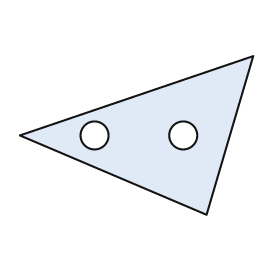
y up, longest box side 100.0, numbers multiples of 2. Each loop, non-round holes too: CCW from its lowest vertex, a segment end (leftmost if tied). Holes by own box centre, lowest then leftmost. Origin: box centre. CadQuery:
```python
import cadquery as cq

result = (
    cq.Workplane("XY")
    .moveTo(30.0, -34.0)
    .lineTo(50.0, 34.0)
    .lineTo(-50.0, 0.0)
    .close()
    .moveTo(-18.0, 0.0)
    .circle(6.0)
    .moveTo(20.0, 0.0)
    .circle(6.0)
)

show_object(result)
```